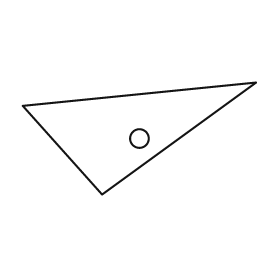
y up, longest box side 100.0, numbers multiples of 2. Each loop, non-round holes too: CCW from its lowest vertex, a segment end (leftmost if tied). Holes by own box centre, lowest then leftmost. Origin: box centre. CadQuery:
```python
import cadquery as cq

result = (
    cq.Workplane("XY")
    .moveTo(-16.0, -24.0)
    .lineTo(50.0, 24.0)
    .lineTo(-50.0, 14.0)
    .close()
    .moveTo(0.0, 0.0)
    .circle(4.0)
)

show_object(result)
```